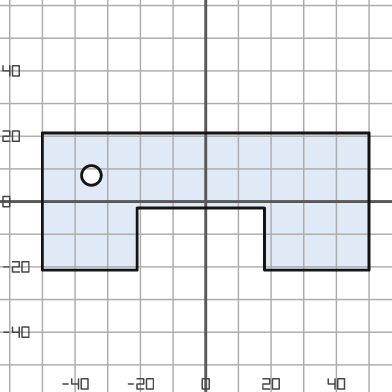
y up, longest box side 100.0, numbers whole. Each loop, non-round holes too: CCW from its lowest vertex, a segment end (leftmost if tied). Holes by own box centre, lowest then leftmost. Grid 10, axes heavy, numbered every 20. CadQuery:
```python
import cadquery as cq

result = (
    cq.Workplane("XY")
    .moveTo(-50.0, -21.0)
    .lineTo(-21.0, -21.0)
    .lineTo(-21.0, -2.0)
    .lineTo(18.0, -2.0)
    .lineTo(18.0, -21.0)
    .lineTo(50.0, -21.0)
    .lineTo(50.0, 21.0)
    .lineTo(-50.0, 21.0)
    .close()
    .moveTo(-35.0, 8.0)
    .circle(3.0)
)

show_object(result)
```